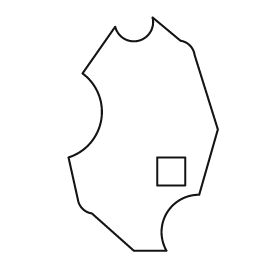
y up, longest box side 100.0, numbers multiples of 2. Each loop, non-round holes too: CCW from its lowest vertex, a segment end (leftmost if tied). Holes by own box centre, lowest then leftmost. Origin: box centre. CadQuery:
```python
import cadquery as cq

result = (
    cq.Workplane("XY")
    .moveTo(-4.0, -50.0)
    .lineTo(10.0, -50.0)
    .threePointArc((10.0, -34.0), (24.0, -26.0))
    .lineTo(32.0, 2.0)
    .lineTo(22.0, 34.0)
    .threePointArc((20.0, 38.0), (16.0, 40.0))
    .lineTo(4.0, 50.0)
    .threePointArc((-2.0, 40.0), (-12.0, 46.0))
    .lineTo(-26.0, 26.0)
    .threePointArc((-18.0, 6.0), (-32.0, -10.0))
    .lineTo(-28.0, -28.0)
    .threePointArc((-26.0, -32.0), (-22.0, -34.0))
    .close()
    .moveTo(6.0, -22.0)
    .lineTo(18.0, -22.0)
    .lineTo(18.0, -10.0)
    .lineTo(6.0, -10.0)
    .close()
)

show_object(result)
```